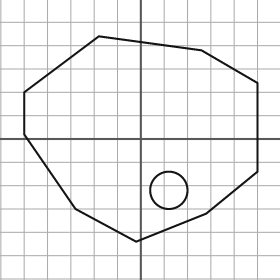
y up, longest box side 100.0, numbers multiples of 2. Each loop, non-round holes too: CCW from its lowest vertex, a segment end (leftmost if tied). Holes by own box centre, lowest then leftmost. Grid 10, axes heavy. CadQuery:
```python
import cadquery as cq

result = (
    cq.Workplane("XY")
    .moveTo(-2.0, -44.0)
    .lineTo(28.0, -32.0)
    .lineTo(50.0, -14.0)
    .lineTo(50.0, 24.0)
    .lineTo(26.0, 38.0)
    .lineTo(-18.0, 44.0)
    .lineTo(-50.0, 20.0)
    .lineTo(-50.0, 2.0)
    .lineTo(-28.0, -30.0)
    .close()
    .moveTo(12.0, -22.0)
    .circle(8.0)
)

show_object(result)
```